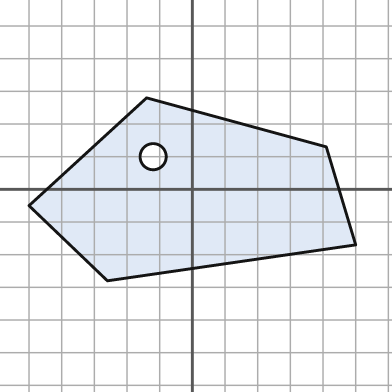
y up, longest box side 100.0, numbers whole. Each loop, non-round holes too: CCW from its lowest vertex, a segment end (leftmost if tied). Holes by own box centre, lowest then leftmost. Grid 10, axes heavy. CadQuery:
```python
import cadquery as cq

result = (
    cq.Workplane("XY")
    .moveTo(-26.0, -28.0)
    .lineTo(50.0, -17.0)
    .lineTo(41.0, 13.0)
    .lineTo(-14.0, 28.0)
    .lineTo(-50.0, -5.0)
    .close()
    .moveTo(-12.0, 10.0)
    .circle(4.0)
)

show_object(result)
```